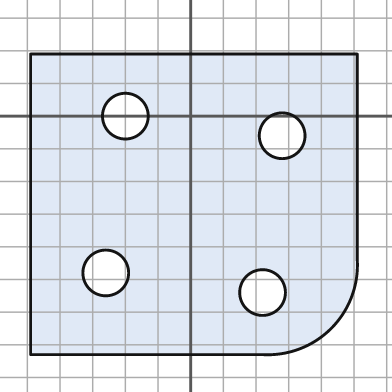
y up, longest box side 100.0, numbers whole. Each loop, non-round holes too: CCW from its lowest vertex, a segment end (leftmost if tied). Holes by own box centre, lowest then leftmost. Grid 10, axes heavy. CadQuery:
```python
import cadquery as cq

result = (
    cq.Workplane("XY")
    .moveTo(-49.0, -73.0)
    .lineTo(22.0, -73.0)
    .threePointArc((43.0, -65.0), (51.0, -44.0))
    .lineTo(51.0, 19.0)
    .lineTo(-49.0, 19.0)
    .close()
    .moveTo(22.0, -54.0)
    .circle(7.0)
    .moveTo(-26.0, -48.0)
    .circle(7.0)
    .moveTo(28.0, -6.0)
    .circle(7.0)
    .moveTo(-20.0, 0.0)
    .circle(7.0)
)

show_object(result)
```